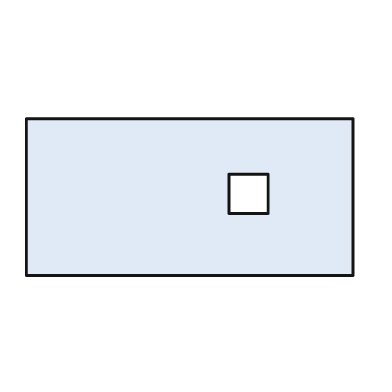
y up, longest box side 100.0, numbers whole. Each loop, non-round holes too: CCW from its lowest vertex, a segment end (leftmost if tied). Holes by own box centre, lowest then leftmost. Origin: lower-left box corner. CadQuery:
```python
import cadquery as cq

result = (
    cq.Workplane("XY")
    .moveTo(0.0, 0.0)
    .lineTo(100.0, 0.0)
    .lineTo(100.0, 48.0)
    .lineTo(0.0, 48.0)
    .close()
    .moveTo(62.0, 19.0)
    .lineTo(74.0, 19.0)
    .lineTo(74.0, 31.0)
    .lineTo(62.0, 31.0)
    .close()
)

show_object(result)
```